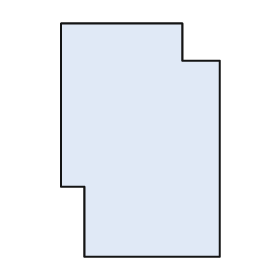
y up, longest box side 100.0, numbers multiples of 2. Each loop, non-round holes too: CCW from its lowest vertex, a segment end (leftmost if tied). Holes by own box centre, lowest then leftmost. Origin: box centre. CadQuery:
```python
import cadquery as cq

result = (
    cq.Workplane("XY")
    .moveTo(-24.0, -50.0)
    .lineTo(34.0, -50.0)
    .lineTo(34.0, 34.0)
    .lineTo(18.0, 34.0)
    .lineTo(18.0, 50.0)
    .lineTo(-34.0, 50.0)
    .lineTo(-34.0, -20.0)
    .lineTo(-24.0, -20.0)
    .close()
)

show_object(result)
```